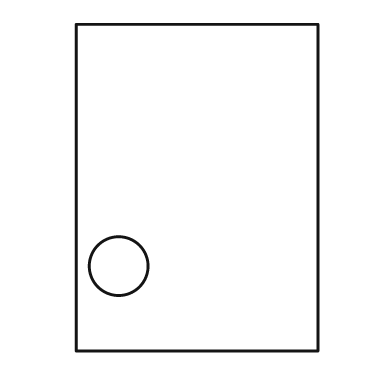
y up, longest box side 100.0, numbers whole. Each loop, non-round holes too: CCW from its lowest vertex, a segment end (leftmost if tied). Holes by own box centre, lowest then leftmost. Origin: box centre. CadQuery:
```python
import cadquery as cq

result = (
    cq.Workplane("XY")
    .moveTo(-37.0, -50.0)
    .lineTo(37.0, -50.0)
    .lineTo(37.0, 50.0)
    .lineTo(-37.0, 50.0)
    .close()
    .moveTo(-24.0, -24.0)
    .circle(9.0)
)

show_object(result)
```